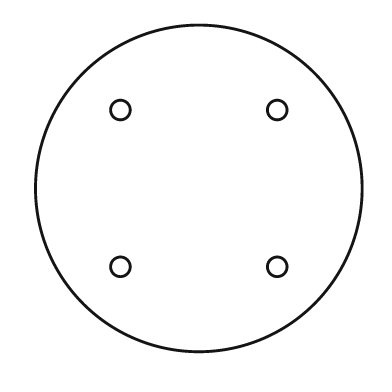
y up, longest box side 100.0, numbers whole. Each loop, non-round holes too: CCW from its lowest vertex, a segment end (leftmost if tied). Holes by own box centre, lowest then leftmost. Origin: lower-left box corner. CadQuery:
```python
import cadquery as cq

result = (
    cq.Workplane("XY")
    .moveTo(50.0, 50.0)
    .circle(50.0)
    .moveTo(26.0, 26.0)
    .circle(3.0)
    .moveTo(74.0, 26.0)
    .circle(3.0)
    .moveTo(26.0, 74.0)
    .circle(3.0)
    .moveTo(74.0, 74.0)
    .circle(3.0)
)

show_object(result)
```